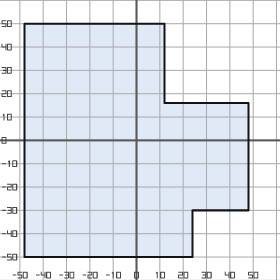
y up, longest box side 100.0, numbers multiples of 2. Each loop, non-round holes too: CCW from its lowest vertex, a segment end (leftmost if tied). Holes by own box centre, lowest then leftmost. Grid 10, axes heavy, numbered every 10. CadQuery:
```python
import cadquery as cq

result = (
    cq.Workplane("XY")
    .moveTo(-48.0, -50.0)
    .lineTo(24.0, -50.0)
    .lineTo(24.0, -30.0)
    .lineTo(48.0, -30.0)
    .lineTo(48.0, 16.0)
    .lineTo(12.0, 16.0)
    .lineTo(12.0, 50.0)
    .lineTo(-48.0, 50.0)
    .close()
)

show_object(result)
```